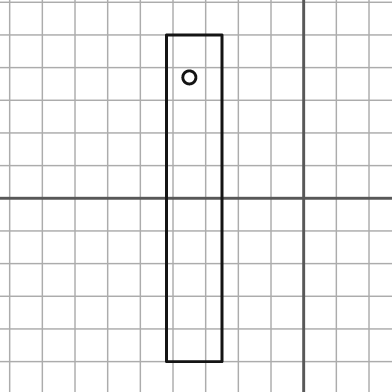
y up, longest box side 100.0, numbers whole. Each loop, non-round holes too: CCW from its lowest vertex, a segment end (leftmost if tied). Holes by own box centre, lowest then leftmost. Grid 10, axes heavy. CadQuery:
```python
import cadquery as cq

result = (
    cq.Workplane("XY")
    .moveTo(-42.0, -50.0)
    .lineTo(-25.0, -50.0)
    .lineTo(-25.0, 50.0)
    .lineTo(-42.0, 50.0)
    .close()
    .moveTo(-35.0, 37.0)
    .circle(2.0)
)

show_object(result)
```